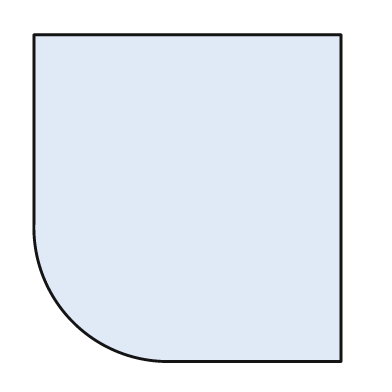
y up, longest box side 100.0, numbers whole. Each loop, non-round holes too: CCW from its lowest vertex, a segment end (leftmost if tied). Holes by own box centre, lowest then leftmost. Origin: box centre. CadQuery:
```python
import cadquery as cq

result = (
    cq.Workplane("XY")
    .moveTo(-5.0, -50.0)
    .lineTo(47.0, -50.0)
    .lineTo(47.0, 50.0)
    .lineTo(-47.0, 50.0)
    .lineTo(-47.0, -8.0)
    .threePointArc((-35.0, -38.0), (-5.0, -50.0))
    .close()
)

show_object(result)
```